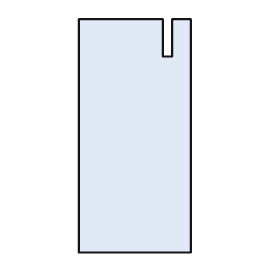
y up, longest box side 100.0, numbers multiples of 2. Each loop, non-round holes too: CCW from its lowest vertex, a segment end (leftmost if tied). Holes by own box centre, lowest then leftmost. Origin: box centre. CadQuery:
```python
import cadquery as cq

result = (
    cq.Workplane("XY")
    .moveTo(-24.0, -50.0)
    .lineTo(24.0, -50.0)
    .lineTo(24.0, 50.0)
    .lineTo(16.0, 50.0)
    .lineTo(16.0, 34.0)
    .lineTo(12.0, 34.0)
    .lineTo(12.0, 50.0)
    .lineTo(-24.0, 50.0)
    .close()
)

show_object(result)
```